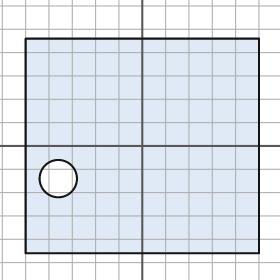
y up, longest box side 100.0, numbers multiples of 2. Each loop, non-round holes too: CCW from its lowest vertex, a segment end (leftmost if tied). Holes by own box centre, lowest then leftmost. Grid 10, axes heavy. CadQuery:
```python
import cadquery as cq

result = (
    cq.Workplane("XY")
    .moveTo(-50.0, -46.0)
    .lineTo(50.0, -46.0)
    .lineTo(50.0, 46.0)
    .lineTo(-50.0, 46.0)
    .close()
    .moveTo(-36.0, -14.0)
    .circle(8.0)
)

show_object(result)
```